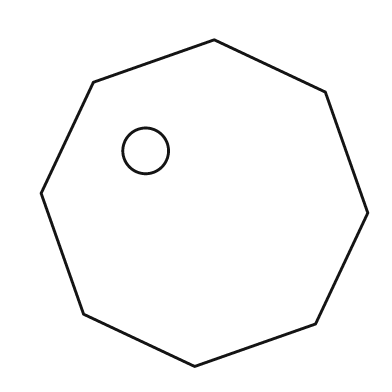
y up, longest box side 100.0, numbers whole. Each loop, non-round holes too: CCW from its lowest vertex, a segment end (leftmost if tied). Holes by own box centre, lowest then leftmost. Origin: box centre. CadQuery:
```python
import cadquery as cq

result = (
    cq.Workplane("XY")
    .moveTo(-3.0, -50.0)
    .lineTo(34.0, -37.0)
    .lineTo(50.0, -3.0)
    .lineTo(37.0, 34.0)
    .lineTo(3.0, 50.0)
    .lineTo(-34.0, 37.0)
    .lineTo(-50.0, 3.0)
    .lineTo(-37.0, -34.0)
    .close()
    .moveTo(-18.0, 16.0)
    .circle(7.0)
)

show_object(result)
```